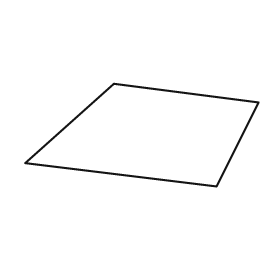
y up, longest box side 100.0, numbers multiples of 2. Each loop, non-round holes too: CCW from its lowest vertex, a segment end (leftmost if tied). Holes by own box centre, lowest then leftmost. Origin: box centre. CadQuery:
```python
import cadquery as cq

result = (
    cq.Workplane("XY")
    .moveTo(32.0, -22.0)
    .lineTo(50.0, 14.0)
    .lineTo(-12.0, 22.0)
    .lineTo(-50.0, -12.0)
    .close()
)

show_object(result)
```